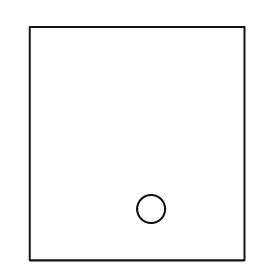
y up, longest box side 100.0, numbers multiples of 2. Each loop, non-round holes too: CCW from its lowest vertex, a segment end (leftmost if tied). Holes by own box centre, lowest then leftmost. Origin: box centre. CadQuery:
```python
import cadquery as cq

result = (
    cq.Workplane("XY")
    .moveTo(-46.0, -50.0)
    .lineTo(46.0, -50.0)
    .lineTo(46.0, 50.0)
    .lineTo(-46.0, 50.0)
    .close()
    .moveTo(6.0, -28.0)
    .circle(6.0)
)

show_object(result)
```